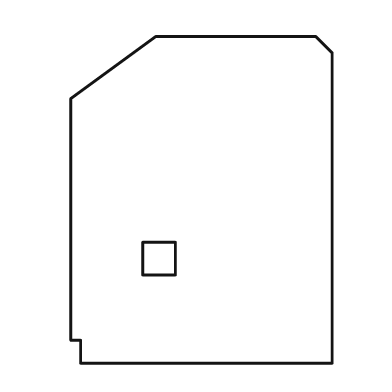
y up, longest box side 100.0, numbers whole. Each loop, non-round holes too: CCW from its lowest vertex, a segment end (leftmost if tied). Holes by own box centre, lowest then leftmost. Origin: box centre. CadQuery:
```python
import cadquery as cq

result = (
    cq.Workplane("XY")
    .moveTo(-37.0, -50.0)
    .lineTo(40.0, -50.0)
    .lineTo(40.0, 45.0)
    .lineTo(35.0, 50.0)
    .lineTo(-14.0, 50.0)
    .lineTo(-40.0, 31.0)
    .lineTo(-40.0, -43.0)
    .lineTo(-37.0, -43.0)
    .close()
    .moveTo(-18.0, -23.0)
    .lineTo(-8.0, -23.0)
    .lineTo(-8.0, -13.0)
    .lineTo(-18.0, -13.0)
    .close()
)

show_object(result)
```